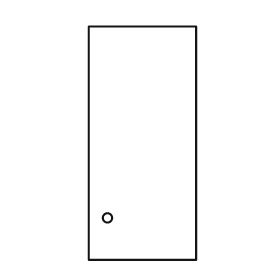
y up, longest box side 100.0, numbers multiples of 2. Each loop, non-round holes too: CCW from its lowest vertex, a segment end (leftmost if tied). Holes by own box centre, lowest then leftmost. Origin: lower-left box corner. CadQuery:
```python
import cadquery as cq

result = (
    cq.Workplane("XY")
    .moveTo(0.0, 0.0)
    .lineTo(46.0, 0.0)
    .lineTo(46.0, 100.0)
    .lineTo(0.0, 100.0)
    .close()
    .moveTo(8.0, 18.0)
    .circle(2.0)
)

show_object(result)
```